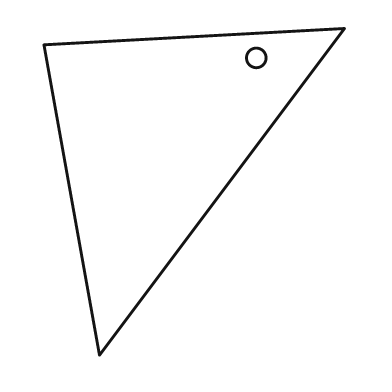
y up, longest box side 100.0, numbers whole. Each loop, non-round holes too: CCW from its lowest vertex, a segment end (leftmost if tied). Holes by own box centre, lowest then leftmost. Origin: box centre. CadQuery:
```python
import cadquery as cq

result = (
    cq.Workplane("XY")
    .moveTo(-29.0, -50.0)
    .lineTo(46.0, 50.0)
    .lineTo(-46.0, 45.0)
    .close()
    .moveTo(19.0, 41.0)
    .circle(3.0)
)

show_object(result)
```